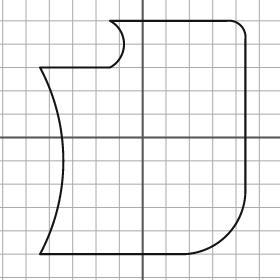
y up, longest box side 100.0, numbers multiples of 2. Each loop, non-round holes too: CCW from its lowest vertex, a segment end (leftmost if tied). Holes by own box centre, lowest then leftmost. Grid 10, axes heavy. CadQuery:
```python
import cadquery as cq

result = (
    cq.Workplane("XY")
    .moveTo(-44.0, -50.0)
    .lineTo(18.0, -50.0)
    .threePointArc((36.0, -42.0), (44.0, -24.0))
    .lineTo(44.0, 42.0)
    .threePointArc((42.0, 48.0), (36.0, 50.0))
    .lineTo(-14.0, 50.0)
    .threePointArc((-8.0, 40.0), (-14.0, 30.0))
    .lineTo(-44.0, 30.0)
    .threePointArc((-34.0, -10.0), (-44.0, -50.0))
    .close()
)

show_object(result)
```